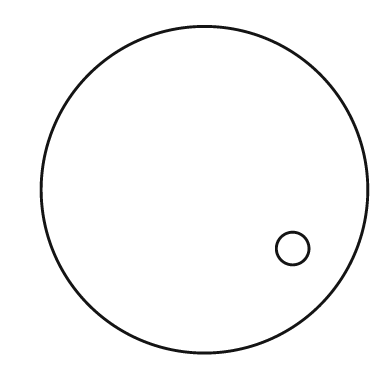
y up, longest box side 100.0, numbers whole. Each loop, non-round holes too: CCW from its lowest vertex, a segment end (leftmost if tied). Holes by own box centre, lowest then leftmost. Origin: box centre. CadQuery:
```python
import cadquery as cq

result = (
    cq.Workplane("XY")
    .moveTo(0.0, 0.0)
    .circle(50.0)
    .moveTo(27.0, -18.0)
    .circle(5.0)
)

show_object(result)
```